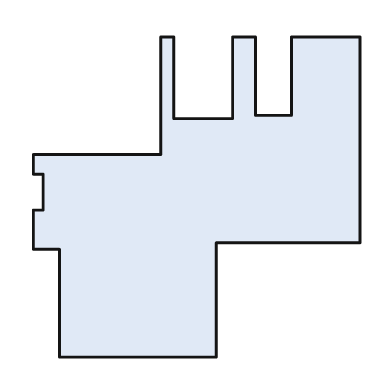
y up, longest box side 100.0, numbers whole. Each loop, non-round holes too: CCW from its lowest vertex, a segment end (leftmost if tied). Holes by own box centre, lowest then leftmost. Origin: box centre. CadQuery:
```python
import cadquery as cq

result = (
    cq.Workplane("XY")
    .moveTo(-42.0, -49.0)
    .lineTo(6.0, -49.0)
    .lineTo(6.0, -14.0)
    .lineTo(50.0, -14.0)
    .lineTo(50.0, 49.0)
    .lineTo(29.0, 49.0)
    .lineTo(29.0, 25.0)
    .lineTo(18.0, 25.0)
    .lineTo(18.0, 49.0)
    .lineTo(11.0, 49.0)
    .lineTo(11.0, 24.0)
    .lineTo(-7.0, 24.0)
    .lineTo(-7.0, 49.0)
    .lineTo(-11.0, 49.0)
    .lineTo(-11.0, 13.0)
    .lineTo(-50.0, 13.0)
    .lineTo(-50.0, 7.0)
    .lineTo(-47.0, 7.0)
    .lineTo(-47.0, -4.0)
    .lineTo(-50.0, -4.0)
    .lineTo(-50.0, -16.0)
    .lineTo(-42.0, -16.0)
    .close()
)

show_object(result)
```